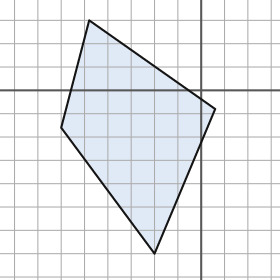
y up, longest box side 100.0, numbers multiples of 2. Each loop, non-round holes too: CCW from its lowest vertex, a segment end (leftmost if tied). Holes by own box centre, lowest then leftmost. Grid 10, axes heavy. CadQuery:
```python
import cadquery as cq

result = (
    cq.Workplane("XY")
    .moveTo(-20.0, -70.0)
    .lineTo(6.0, -8.0)
    .lineTo(-48.0, 30.0)
    .lineTo(-60.0, -16.0)
    .close()
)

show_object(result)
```